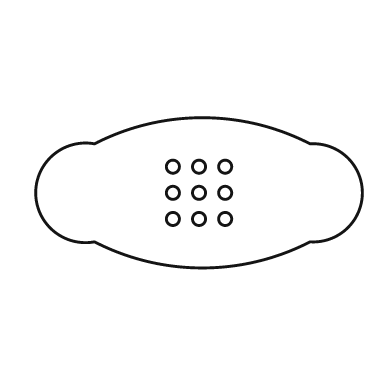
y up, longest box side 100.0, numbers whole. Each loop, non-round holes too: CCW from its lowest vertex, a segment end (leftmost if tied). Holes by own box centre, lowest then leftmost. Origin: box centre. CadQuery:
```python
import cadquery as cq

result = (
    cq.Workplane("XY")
    .moveTo(-32.0, -15.0)
    .threePointArc((1.0, -23.0), (34.0, -15.0))
    .threePointArc((50.0, 0.0), (34.0, 15.0))
    .threePointArc((1.0, 23.0), (-32.0, 15.0))
    .threePointArc((-50.0, 0.0), (-32.0, -15.0))
    .close()
    .moveTo(-8.0, -8.0)
    .circle(2.0)
    .moveTo(0.0, -8.0)
    .circle(2.0)
    .moveTo(8.0, -8.0)
    .circle(2.0)
    .moveTo(-8.0, 0.0)
    .circle(2.0)
    .moveTo(0.0, 0.0)
    .circle(2.0)
    .moveTo(8.0, 0.0)
    .circle(2.0)
    .moveTo(-8.0, 8.0)
    .circle(2.0)
    .moveTo(0.0, 8.0)
    .circle(2.0)
    .moveTo(8.0, 8.0)
    .circle(2.0)
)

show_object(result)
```